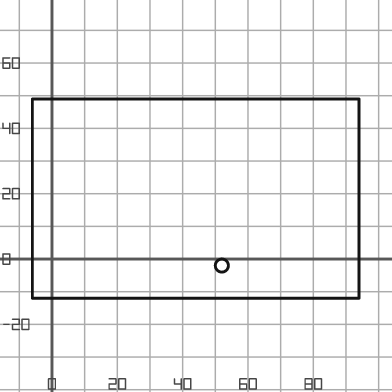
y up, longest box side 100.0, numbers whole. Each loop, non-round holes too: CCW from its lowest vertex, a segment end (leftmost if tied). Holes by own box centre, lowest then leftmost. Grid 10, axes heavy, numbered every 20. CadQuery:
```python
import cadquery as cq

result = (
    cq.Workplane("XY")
    .moveTo(-6.0, -12.0)
    .lineTo(94.0, -12.0)
    .lineTo(94.0, 49.0)
    .lineTo(-6.0, 49.0)
    .close()
    .moveTo(52.0, -2.0)
    .circle(2.0)
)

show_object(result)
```